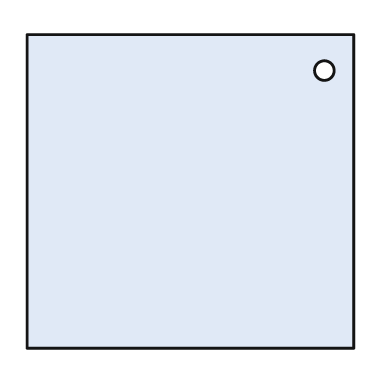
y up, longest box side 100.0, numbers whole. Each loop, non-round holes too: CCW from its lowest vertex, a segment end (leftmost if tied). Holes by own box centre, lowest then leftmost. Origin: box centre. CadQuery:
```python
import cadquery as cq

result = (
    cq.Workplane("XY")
    .moveTo(-50.0, -48.0)
    .lineTo(50.0, -48.0)
    .lineTo(50.0, 48.0)
    .lineTo(-50.0, 48.0)
    .close()
    .moveTo(41.0, 37.0)
    .circle(3.0)
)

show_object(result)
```